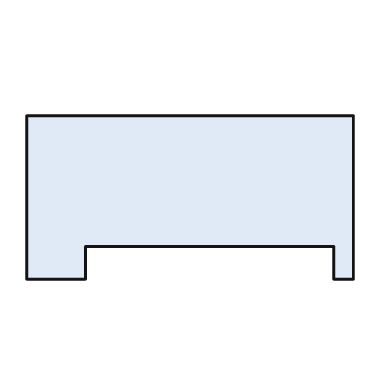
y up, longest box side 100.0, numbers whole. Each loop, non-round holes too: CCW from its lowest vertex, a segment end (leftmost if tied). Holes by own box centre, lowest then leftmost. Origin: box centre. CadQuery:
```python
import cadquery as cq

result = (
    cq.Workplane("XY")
    .moveTo(-50.0, -25.0)
    .lineTo(-32.0, -25.0)
    .lineTo(-32.0, -15.0)
    .lineTo(44.0, -15.0)
    .lineTo(44.0, -25.0)
    .lineTo(50.0, -25.0)
    .lineTo(50.0, 25.0)
    .lineTo(-50.0, 25.0)
    .close()
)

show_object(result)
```